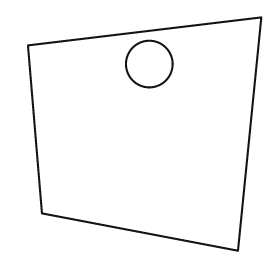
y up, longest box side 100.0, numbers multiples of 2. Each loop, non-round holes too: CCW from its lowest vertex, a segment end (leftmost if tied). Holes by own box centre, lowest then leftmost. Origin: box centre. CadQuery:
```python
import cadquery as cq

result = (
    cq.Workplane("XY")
    .moveTo(40.0, -50.0)
    .lineTo(50.0, 50.0)
    .lineTo(-50.0, 38.0)
    .lineTo(-44.0, -34.0)
    .close()
    .moveTo(2.0, 30.0)
    .circle(10.0)
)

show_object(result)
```